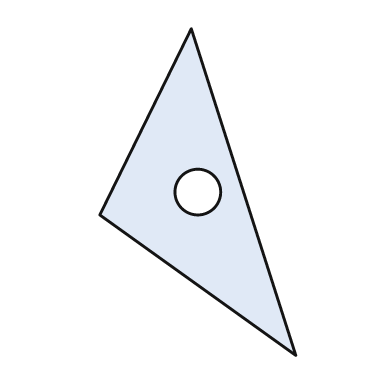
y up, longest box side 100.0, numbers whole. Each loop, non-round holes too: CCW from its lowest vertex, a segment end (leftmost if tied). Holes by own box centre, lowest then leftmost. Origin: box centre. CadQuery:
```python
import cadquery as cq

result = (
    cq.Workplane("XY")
    .moveTo(30.0, -50.0)
    .lineTo(-2.0, 50.0)
    .lineTo(-30.0, -7.0)
    .close()
    .moveTo(0.0, 0.0)
    .circle(7.0)
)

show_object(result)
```